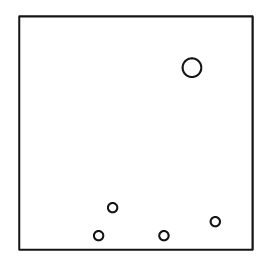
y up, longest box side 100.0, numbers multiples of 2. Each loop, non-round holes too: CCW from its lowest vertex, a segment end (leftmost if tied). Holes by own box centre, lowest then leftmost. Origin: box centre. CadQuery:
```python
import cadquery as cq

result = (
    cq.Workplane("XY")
    .moveTo(-50.0, -50.0)
    .lineTo(50.0, -50.0)
    .lineTo(50.0, 50.0)
    .lineTo(-50.0, 50.0)
    .close()
    .moveTo(-16.0, -44.0)
    .circle(2.0)
    .moveTo(12.0, -44.0)
    .circle(2.0)
    .moveTo(34.0, -38.0)
    .circle(2.0)
    .moveTo(-10.0, -32.0)
    .circle(2.0)
    .moveTo(24.0, 28.0)
    .circle(4.0)
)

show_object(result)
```